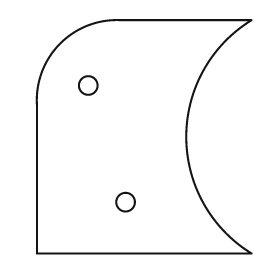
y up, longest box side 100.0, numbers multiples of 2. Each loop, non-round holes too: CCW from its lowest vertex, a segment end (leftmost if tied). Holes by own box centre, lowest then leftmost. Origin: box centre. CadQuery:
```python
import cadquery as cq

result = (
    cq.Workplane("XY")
    .moveTo(-46.0, -50.0)
    .lineTo(46.0, -50.0)
    .threePointArc((18.0, 0.0), (46.0, 50.0))
    .lineTo(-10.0, 50.0)
    .threePointArc((-36.0, 40.0), (-46.0, 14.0))
    .close()
    .moveTo(-8.0, -28.0)
    .circle(4.0)
    .moveTo(-24.0, 22.0)
    .circle(4.0)
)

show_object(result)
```